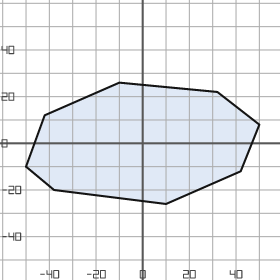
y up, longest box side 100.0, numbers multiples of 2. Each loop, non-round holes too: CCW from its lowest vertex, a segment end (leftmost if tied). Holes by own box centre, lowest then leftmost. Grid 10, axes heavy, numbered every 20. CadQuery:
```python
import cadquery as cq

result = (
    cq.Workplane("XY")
    .moveTo(10.0, -26.0)
    .lineTo(42.0, -12.0)
    .lineTo(50.0, 8.0)
    .lineTo(32.0, 22.0)
    .lineTo(-10.0, 26.0)
    .lineTo(-42.0, 12.0)
    .lineTo(-50.0, -10.0)
    .lineTo(-38.0, -20.0)
    .close()
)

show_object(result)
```